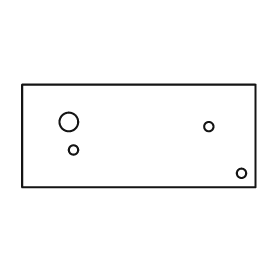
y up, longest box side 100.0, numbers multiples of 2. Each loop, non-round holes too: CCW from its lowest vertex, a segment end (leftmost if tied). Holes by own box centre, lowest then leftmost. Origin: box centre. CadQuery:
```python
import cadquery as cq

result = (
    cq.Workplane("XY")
    .moveTo(-50.0, -22.0)
    .lineTo(50.0, -22.0)
    .lineTo(50.0, 22.0)
    .lineTo(-50.0, 22.0)
    .close()
    .moveTo(44.0, -16.0)
    .circle(2.0)
    .moveTo(-28.0, -6.0)
    .circle(2.0)
    .moveTo(30.0, 4.0)
    .circle(2.0)
    .moveTo(-30.0, 6.0)
    .circle(4.0)
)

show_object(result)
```